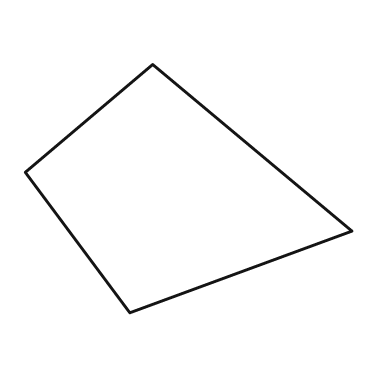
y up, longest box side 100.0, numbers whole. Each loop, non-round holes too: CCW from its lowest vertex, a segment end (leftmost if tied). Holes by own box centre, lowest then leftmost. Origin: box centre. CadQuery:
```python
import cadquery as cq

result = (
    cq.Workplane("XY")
    .moveTo(-18.0, -38.0)
    .lineTo(50.0, -13.0)
    .lineTo(-11.0, 38.0)
    .lineTo(-50.0, 5.0)
    .close()
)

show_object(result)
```